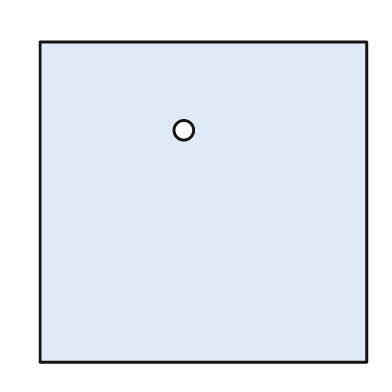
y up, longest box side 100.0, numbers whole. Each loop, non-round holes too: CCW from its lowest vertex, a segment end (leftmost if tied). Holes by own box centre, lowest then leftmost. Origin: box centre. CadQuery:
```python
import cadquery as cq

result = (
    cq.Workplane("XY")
    .moveTo(-50.0, -49.0)
    .lineTo(50.0, -49.0)
    .lineTo(50.0, 49.0)
    .lineTo(-50.0, 49.0)
    .close()
    .moveTo(-6.0, 22.0)
    .circle(3.0)
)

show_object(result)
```